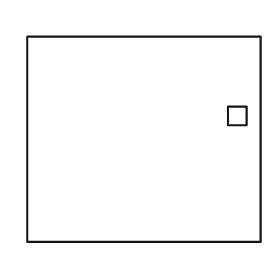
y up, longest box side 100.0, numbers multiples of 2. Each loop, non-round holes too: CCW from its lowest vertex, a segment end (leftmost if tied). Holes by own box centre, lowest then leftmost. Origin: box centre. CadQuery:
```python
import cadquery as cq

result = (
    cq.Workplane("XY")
    .moveTo(-50.0, -44.0)
    .lineTo(50.0, -44.0)
    .lineTo(50.0, 44.0)
    .lineTo(-50.0, 44.0)
    .close()
    .moveTo(36.0, 6.0)
    .lineTo(44.0, 6.0)
    .lineTo(44.0, 14.0)
    .lineTo(36.0, 14.0)
    .close()
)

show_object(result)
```